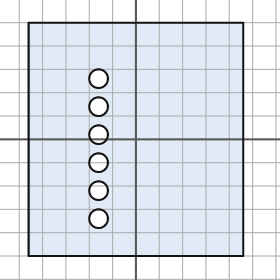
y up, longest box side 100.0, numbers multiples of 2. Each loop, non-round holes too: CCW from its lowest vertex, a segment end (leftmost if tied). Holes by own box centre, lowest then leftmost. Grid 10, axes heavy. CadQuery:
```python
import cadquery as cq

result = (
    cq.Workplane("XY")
    .moveTo(-46.0, -50.0)
    .lineTo(46.0, -50.0)
    .lineTo(46.0, 50.0)
    .lineTo(-46.0, 50.0)
    .close()
    .moveTo(-16.0, -34.0)
    .circle(4.0)
    .moveTo(-16.0, -22.0)
    .circle(4.0)
    .moveTo(-16.0, -10.0)
    .circle(4.0)
    .moveTo(-16.0, 2.0)
    .circle(4.0)
    .moveTo(-16.0, 14.0)
    .circle(4.0)
    .moveTo(-16.0, 26.0)
    .circle(4.0)
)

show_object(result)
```